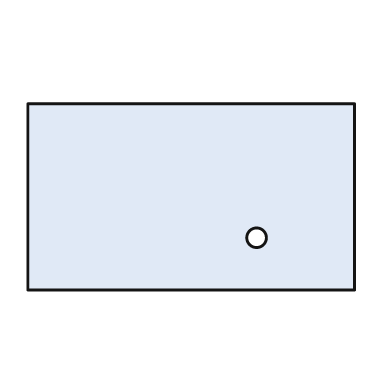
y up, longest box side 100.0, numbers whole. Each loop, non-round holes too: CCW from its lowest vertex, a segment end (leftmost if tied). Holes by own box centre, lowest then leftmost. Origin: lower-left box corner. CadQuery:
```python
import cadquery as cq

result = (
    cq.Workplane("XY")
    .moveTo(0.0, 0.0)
    .lineTo(100.0, 0.0)
    .lineTo(100.0, 57.0)
    .lineTo(0.0, 57.0)
    .close()
    .moveTo(70.0, 16.0)
    .circle(3.0)
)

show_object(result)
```